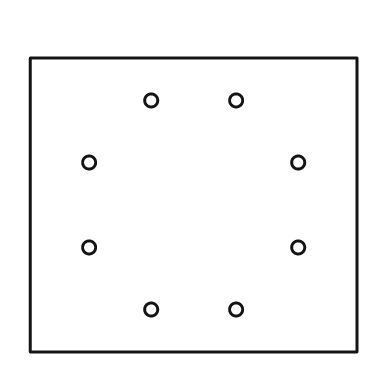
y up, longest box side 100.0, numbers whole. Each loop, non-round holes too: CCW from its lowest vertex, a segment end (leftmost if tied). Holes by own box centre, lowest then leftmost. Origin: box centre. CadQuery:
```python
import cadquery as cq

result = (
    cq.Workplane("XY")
    .moveTo(-50.0, -45.0)
    .lineTo(50.0, -45.0)
    .lineTo(50.0, 45.0)
    .lineTo(-50.0, 45.0)
    .close()
    .moveTo(-13.0, -32.0)
    .circle(2.0)
    .moveTo(13.0, -32.0)
    .circle(2.0)
    .moveTo(-32.0, -13.0)
    .circle(2.0)
    .moveTo(32.0, -13.0)
    .circle(2.0)
    .moveTo(-32.0, 13.0)
    .circle(2.0)
    .moveTo(32.0, 13.0)
    .circle(2.0)
    .moveTo(-13.0, 32.0)
    .circle(2.0)
    .moveTo(13.0, 32.0)
    .circle(2.0)
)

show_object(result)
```